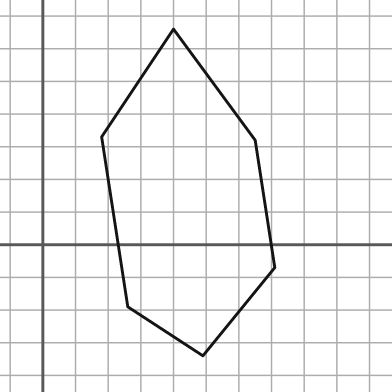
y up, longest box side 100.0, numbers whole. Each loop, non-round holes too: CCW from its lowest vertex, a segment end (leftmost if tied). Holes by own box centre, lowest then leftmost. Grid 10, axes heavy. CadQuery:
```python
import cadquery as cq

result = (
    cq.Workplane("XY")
    .moveTo(49.0, -34.0)
    .lineTo(71.0, -7.0)
    .lineTo(65.0, 32.0)
    .lineTo(40.0, 66.0)
    .lineTo(18.0, 33.0)
    .lineTo(26.0, -19.0)
    .close()
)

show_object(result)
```